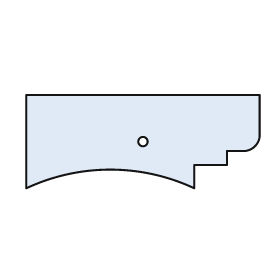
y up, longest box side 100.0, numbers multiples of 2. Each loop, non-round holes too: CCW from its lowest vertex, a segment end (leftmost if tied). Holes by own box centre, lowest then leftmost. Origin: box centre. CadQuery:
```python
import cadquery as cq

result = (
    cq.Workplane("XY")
    .moveTo(-50.0, -20.0)
    .threePointArc((-14.0, -12.0), (22.0, -20.0))
    .lineTo(22.0, -10.0)
    .lineTo(36.0, -10.0)
    .lineTo(36.0, -4.0)
    .lineTo(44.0, -4.0)
    .threePointArc((48.0, -2.0), (50.0, 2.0))
    .lineTo(50.0, 20.0)
    .lineTo(-50.0, 20.0)
    .close()
    .moveTo(0.0, 0.0)
    .circle(2.0)
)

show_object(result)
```